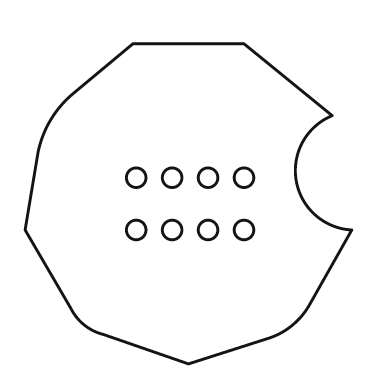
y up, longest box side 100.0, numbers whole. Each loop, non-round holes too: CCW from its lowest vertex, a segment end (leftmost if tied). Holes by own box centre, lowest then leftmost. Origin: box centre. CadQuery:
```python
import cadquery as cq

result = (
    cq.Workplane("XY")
    .moveTo(0.0, -49.0)
    .lineTo(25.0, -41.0)
    .threePointArc((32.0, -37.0), (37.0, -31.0))
    .lineTo(50.0, -8.0)
    .threePointArc((33.0, 7.0), (44.0, 27.0))
    .lineTo(17.0, 49.0)
    .lineTo(-17.0, 49.0)
    .lineTo(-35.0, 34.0)
    .threePointArc((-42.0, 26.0), (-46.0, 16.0))
    .lineTo(-50.0, -8.0)
    .lineTo(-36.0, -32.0)
    .threePointArc((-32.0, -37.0), (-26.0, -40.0))
    .close()
    .moveTo(-16.0, -8.0)
    .circle(3.0)
    .moveTo(-5.0, -8.0)
    .circle(3.0)
    .moveTo(6.0, -8.0)
    .circle(3.0)
    .moveTo(17.0, -8.0)
    .circle(3.0)
    .moveTo(-16.0, 8.0)
    .circle(3.0)
    .moveTo(-5.0, 8.0)
    .circle(3.0)
    .moveTo(6.0, 8.0)
    .circle(3.0)
    .moveTo(17.0, 8.0)
    .circle(3.0)
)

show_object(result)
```